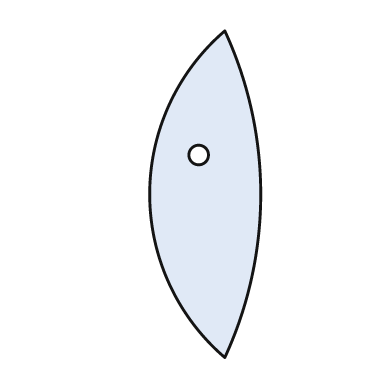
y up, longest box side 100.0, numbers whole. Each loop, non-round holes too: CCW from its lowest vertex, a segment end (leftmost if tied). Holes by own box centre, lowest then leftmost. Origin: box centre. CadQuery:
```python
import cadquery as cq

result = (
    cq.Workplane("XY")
    .moveTo(6.0, -50.0)
    .threePointArc((17.0, 0.0), (6.0, 50.0))
    .threePointArc((-17.0, 0.0), (6.0, -50.0))
    .close()
    .moveTo(-2.0, 12.0)
    .circle(3.0)
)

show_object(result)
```